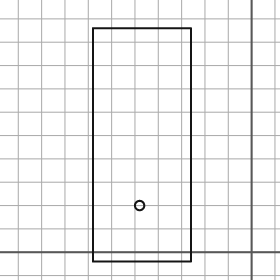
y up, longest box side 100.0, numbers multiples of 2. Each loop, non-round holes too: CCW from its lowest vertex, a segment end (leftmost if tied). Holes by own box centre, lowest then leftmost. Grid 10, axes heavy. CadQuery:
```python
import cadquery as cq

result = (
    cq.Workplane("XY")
    .moveTo(-68.0, -4.0)
    .lineTo(-26.0, -4.0)
    .lineTo(-26.0, 96.0)
    .lineTo(-68.0, 96.0)
    .close()
    .moveTo(-48.0, 20.0)
    .circle(2.0)
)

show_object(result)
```